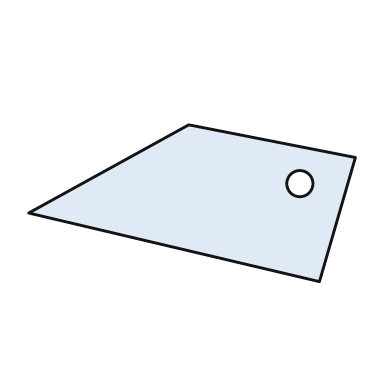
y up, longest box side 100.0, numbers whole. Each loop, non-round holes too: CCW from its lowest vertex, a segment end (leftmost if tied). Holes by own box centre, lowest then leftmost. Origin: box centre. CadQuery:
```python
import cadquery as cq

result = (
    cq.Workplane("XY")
    .moveTo(39.0, -24.0)
    .lineTo(50.0, 14.0)
    .lineTo(-1.0, 24.0)
    .lineTo(-50.0, -3.0)
    .close()
    .moveTo(33.0, 6.0)
    .circle(4.0)
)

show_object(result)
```